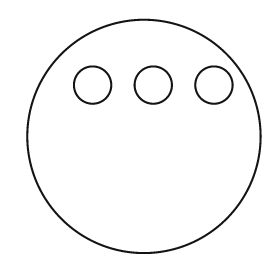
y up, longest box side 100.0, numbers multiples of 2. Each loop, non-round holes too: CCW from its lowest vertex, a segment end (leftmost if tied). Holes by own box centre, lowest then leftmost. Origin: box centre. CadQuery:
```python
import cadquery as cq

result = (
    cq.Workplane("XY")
    .moveTo(0.0, 0.0)
    .circle(50.0)
    .moveTo(-22.0, 22.0)
    .circle(8.0)
    .moveTo(4.0, 22.0)
    .circle(8.0)
    .moveTo(30.0, 22.0)
    .circle(8.0)
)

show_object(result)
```